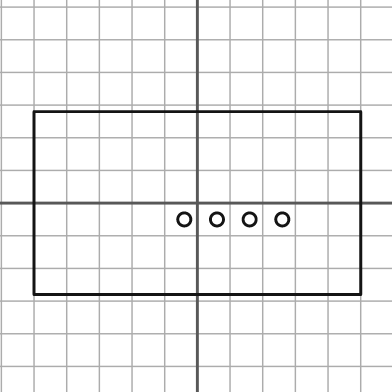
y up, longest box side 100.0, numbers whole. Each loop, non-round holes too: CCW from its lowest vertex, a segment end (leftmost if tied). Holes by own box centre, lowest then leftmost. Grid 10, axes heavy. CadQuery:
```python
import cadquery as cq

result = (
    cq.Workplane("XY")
    .moveTo(-50.0, -28.0)
    .lineTo(50.0, -28.0)
    .lineTo(50.0, 28.0)
    .lineTo(-50.0, 28.0)
    .close()
    .moveTo(-4.0, -5.0)
    .circle(2.0)
    .moveTo(6.0, -5.0)
    .circle(2.0)
    .moveTo(16.0, -5.0)
    .circle(2.0)
    .moveTo(26.0, -5.0)
    .circle(2.0)
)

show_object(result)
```